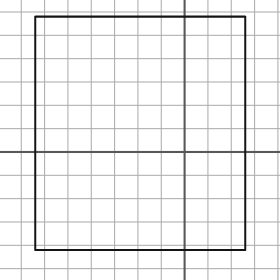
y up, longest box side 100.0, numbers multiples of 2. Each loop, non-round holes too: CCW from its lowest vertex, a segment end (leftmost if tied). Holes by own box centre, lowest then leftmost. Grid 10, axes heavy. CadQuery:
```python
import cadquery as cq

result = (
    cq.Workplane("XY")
    .moveTo(-64.0, -42.0)
    .lineTo(26.0, -42.0)
    .lineTo(26.0, 58.0)
    .lineTo(-64.0, 58.0)
    .close()
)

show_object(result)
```